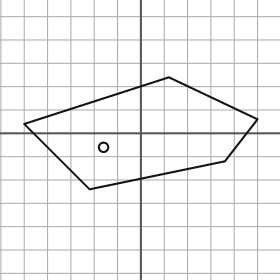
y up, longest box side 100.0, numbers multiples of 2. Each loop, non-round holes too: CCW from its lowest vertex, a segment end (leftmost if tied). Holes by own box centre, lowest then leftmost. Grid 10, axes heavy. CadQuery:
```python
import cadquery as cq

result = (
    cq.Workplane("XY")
    .moveTo(-22.0, -24.0)
    .lineTo(36.0, -12.0)
    .lineTo(50.0, 6.0)
    .lineTo(12.0, 24.0)
    .lineTo(-50.0, 4.0)
    .close()
    .moveTo(-16.0, -6.0)
    .circle(2.0)
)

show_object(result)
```